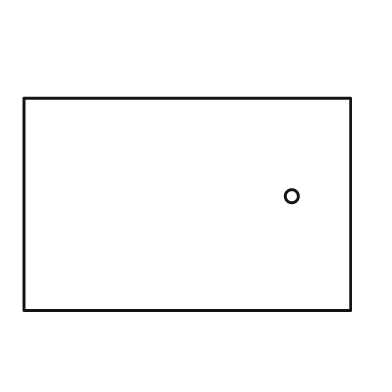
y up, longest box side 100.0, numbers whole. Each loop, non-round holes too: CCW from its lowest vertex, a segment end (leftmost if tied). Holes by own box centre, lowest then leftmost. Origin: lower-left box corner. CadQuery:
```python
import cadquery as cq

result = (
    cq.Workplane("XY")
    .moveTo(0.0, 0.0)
    .lineTo(100.0, 0.0)
    .lineTo(100.0, 65.0)
    .lineTo(0.0, 65.0)
    .close()
    .moveTo(82.0, 35.0)
    .circle(2.0)
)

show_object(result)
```